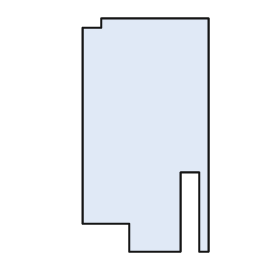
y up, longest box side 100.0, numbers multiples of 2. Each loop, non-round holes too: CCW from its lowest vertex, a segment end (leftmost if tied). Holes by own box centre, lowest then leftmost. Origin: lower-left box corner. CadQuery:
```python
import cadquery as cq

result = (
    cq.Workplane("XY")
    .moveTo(20.0, 0.0)
    .lineTo(42.0, 0.0)
    .lineTo(42.0, 34.0)
    .lineTo(50.0, 34.0)
    .lineTo(50.0, 0.0)
    .lineTo(54.0, 0.0)
    .lineTo(54.0, 100.0)
    .lineTo(8.0, 100.0)
    .lineTo(8.0, 96.0)
    .lineTo(0.0, 96.0)
    .lineTo(0.0, 12.0)
    .lineTo(20.0, 12.0)
    .close()
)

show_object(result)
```